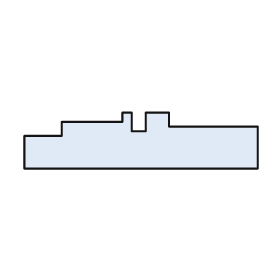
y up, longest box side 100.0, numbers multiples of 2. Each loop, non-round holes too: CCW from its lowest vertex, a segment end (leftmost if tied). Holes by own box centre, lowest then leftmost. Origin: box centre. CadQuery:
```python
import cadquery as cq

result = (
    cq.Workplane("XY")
    .moveTo(-50.0, -12.0)
    .lineTo(50.0, -12.0)
    .lineTo(50.0, 6.0)
    .lineTo(12.0, 6.0)
    .lineTo(12.0, 12.0)
    .lineTo(2.0, 12.0)
    .lineTo(2.0, 4.0)
    .lineTo(-4.0, 4.0)
    .lineTo(-4.0, 12.0)
    .lineTo(-8.0, 12.0)
    .lineTo(-8.0, 8.0)
    .lineTo(-34.0, 8.0)
    .lineTo(-34.0, 2.0)
    .lineTo(-50.0, 2.0)
    .close()
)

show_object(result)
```